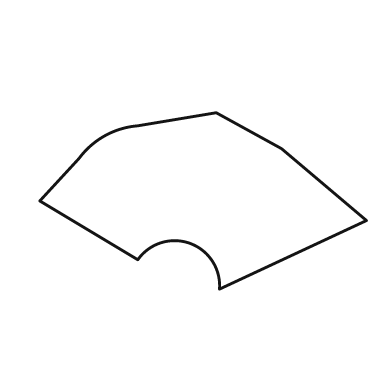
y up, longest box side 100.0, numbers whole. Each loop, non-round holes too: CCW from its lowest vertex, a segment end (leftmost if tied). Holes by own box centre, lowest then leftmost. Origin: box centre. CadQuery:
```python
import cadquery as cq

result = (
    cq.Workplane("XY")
    .moveTo(5.0, -27.0)
    .lineTo(50.0, -6.0)
    .lineTo(24.0, 16.0)
    .lineTo(4.0, 27.0)
    .lineTo(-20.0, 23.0)
    .threePointArc((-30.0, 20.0), (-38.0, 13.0))
    .lineTo(-50.0, 0.0)
    .lineTo(-20.0, -18.0)
    .threePointArc((-4.0, -13.0), (5.0, -27.0))
    .close()
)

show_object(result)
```